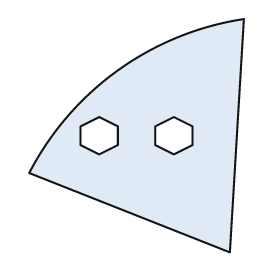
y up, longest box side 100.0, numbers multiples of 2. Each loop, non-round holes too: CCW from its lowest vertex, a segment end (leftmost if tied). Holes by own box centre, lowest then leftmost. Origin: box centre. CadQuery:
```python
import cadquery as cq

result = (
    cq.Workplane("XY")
    .moveTo(40.0, -50.0)
    .lineTo(46.0, 50.0)
    .threePointArc((-8.0, 28.0), (-46.0, -16.0))
    .close()
    .moveTo(-16.0, -8.0)
    .lineTo(-8.0, -4.0)
    .lineTo(-8.0, 4.0)
    .lineTo(-16.0, 8.0)
    .lineTo(-24.0, 4.0)
    .lineTo(-24.0, -4.0)
    .close()
    .moveTo(16.0, -8.0)
    .lineTo(24.0, -4.0)
    .lineTo(24.0, 4.0)
    .lineTo(16.0, 8.0)
    .lineTo(8.0, 4.0)
    .lineTo(8.0, -4.0)
    .close()
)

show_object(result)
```